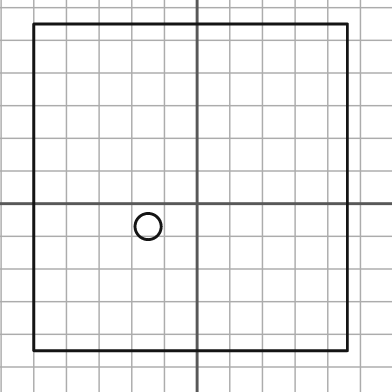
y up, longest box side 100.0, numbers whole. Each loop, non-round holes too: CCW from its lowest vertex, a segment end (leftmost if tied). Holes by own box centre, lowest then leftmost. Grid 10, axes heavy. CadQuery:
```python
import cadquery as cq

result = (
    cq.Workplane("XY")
    .moveTo(-50.0, -45.0)
    .lineTo(46.0, -45.0)
    .lineTo(46.0, 55.0)
    .lineTo(-50.0, 55.0)
    .close()
    .moveTo(-15.0, -7.0)
    .circle(4.0)
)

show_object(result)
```